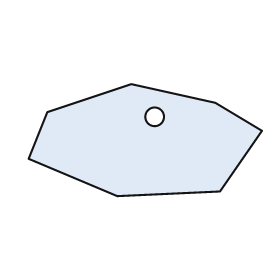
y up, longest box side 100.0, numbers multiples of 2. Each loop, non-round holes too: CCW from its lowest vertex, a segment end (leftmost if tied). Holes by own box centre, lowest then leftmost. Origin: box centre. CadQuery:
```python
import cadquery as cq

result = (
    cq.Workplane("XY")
    .moveTo(-12.0, -24.0)
    .lineTo(32.0, -22.0)
    .lineTo(50.0, 4.0)
    .lineTo(30.0, 16.0)
    .lineTo(-6.0, 24.0)
    .lineTo(-42.0, 12.0)
    .lineTo(-50.0, -8.0)
    .close()
    .moveTo(4.0, 10.0)
    .circle(4.0)
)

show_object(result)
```